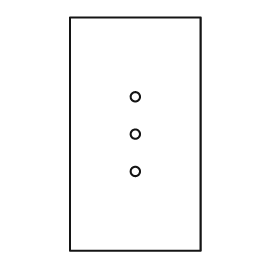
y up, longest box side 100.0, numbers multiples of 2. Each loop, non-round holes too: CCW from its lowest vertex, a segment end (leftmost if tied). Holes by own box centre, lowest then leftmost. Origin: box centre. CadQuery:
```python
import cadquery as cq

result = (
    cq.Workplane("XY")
    .moveTo(-28.0, -50.0)
    .lineTo(28.0, -50.0)
    .lineTo(28.0, 50.0)
    .lineTo(-28.0, 50.0)
    .close()
    .moveTo(0.0, -16.0)
    .circle(2.0)
    .moveTo(0.0, 0.0)
    .circle(2.0)
    .moveTo(0.0, 16.0)
    .circle(2.0)
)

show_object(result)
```